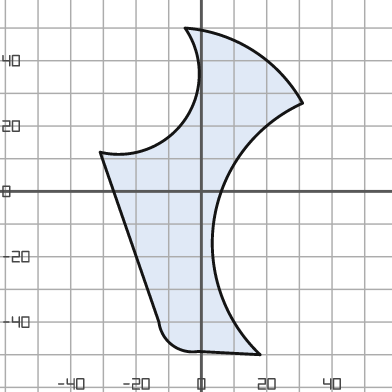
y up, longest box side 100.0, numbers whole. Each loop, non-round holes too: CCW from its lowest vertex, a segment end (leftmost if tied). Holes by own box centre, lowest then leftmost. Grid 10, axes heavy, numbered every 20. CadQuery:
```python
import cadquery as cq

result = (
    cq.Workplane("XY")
    .moveTo(18.0, -50.0)
    .threePointArc((4.0, -8.0), (31.0, 27.0))
    .threePointArc((16.0, 43.0), (-5.0, 50.0))
    .threePointArc((-5.0, 22.0), (-31.0, 12.0))
    .lineTo(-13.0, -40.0)
    .threePointArc((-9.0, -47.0), (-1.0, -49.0))
    .close()
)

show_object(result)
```